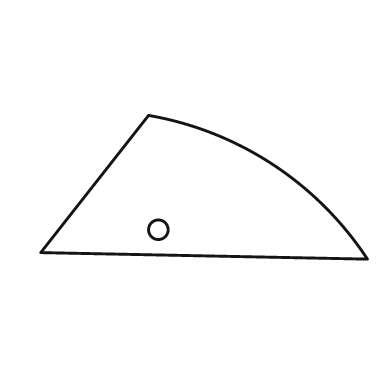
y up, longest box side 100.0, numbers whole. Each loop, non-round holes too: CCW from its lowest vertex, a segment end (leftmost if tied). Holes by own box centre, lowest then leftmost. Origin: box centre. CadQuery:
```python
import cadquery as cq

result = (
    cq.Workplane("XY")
    .moveTo(50.0, -22.0)
    .threePointArc((21.0, 7.0), (-17.0, 22.0))
    .lineTo(-50.0, -20.0)
    .close()
    .moveTo(-14.0, -13.0)
    .circle(3.0)
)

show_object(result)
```